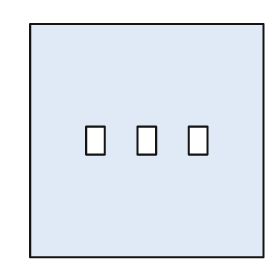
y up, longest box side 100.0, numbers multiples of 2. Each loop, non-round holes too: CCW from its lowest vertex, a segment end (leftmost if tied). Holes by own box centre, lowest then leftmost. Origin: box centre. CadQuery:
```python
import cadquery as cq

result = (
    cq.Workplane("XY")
    .moveTo(-50.0, -50.0)
    .lineTo(50.0, -50.0)
    .lineTo(50.0, 50.0)
    .lineTo(-50.0, 50.0)
    .close()
    .moveTo(-26.0, -6.0)
    .lineTo(-18.0, -6.0)
    .lineTo(-18.0, 6.0)
    .lineTo(-26.0, 6.0)
    .close()
    .moveTo(-4.0, -6.0)
    .lineTo(4.0, -6.0)
    .lineTo(4.0, 6.0)
    .lineTo(-4.0, 6.0)
    .close()
    .moveTo(18.0, -6.0)
    .lineTo(26.0, -6.0)
    .lineTo(26.0, 6.0)
    .lineTo(18.0, 6.0)
    .close()
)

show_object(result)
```